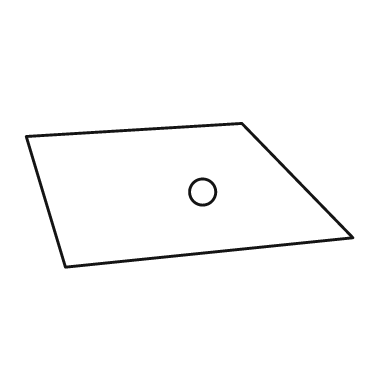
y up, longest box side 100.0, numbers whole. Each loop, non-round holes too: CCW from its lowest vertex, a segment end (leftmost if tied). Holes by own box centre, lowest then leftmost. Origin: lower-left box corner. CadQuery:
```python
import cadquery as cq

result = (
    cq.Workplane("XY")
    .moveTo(12.0, 0.0)
    .lineTo(100.0, 9.0)
    .lineTo(66.0, 44.0)
    .lineTo(0.0, 40.0)
    .close()
    .moveTo(54.0, 23.0)
    .circle(4.0)
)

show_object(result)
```